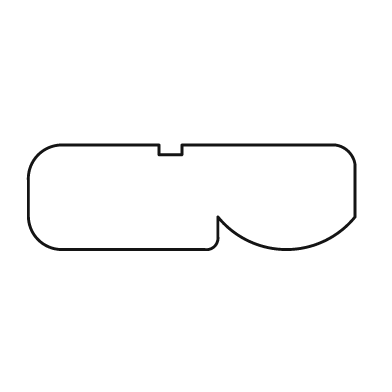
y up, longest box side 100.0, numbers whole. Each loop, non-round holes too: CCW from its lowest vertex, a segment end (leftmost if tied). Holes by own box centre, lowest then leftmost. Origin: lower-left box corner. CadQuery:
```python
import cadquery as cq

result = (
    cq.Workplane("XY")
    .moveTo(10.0, 0.0)
    .lineTo(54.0, 0.0)
    .threePointArc((57.0, 1.0), (58.0, 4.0))
    .lineTo(58.0, 10.0)
    .threePointArc((79.0, 0.0), (100.0, 10.0))
    .lineTo(100.0, 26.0)
    .threePointArc((98.0, 30.0), (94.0, 32.0))
    .lineTo(47.0, 32.0)
    .lineTo(47.0, 29.0)
    .lineTo(40.0, 29.0)
    .lineTo(40.0, 32.0)
    .lineTo(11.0, 32.0)
    .threePointArc((3.0, 29.0), (0.0, 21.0))
    .lineTo(0.0, 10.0)
    .threePointArc((3.0, 3.0), (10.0, 0.0))
    .close()
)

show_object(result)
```